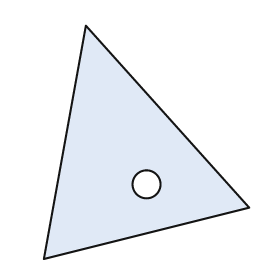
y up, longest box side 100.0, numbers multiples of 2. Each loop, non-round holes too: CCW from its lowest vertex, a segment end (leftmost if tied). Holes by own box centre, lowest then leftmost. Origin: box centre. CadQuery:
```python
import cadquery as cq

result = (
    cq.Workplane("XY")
    .moveTo(-44.0, -50.0)
    .lineTo(44.0, -28.0)
    .lineTo(-26.0, 50.0)
    .close()
    .moveTo(0.0, -18.0)
    .circle(6.0)
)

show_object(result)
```